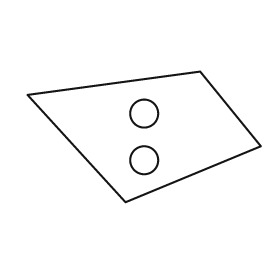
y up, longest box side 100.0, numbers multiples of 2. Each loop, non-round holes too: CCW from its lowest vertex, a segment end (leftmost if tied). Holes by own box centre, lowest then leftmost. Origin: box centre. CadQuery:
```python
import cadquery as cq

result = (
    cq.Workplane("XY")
    .moveTo(-8.0, -28.0)
    .lineTo(50.0, -4.0)
    .lineTo(24.0, 28.0)
    .lineTo(-50.0, 18.0)
    .close()
    .moveTo(0.0, -10.0)
    .circle(6.0)
    .moveTo(0.0, 10.0)
    .circle(6.0)
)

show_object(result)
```